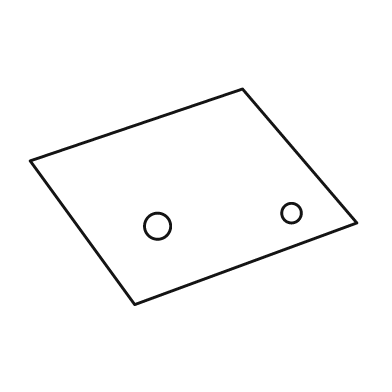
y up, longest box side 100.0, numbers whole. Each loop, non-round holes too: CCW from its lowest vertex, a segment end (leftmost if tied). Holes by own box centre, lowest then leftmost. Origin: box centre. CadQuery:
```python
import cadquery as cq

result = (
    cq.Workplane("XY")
    .moveTo(-18.0, -33.0)
    .lineTo(50.0, -8.0)
    .lineTo(15.0, 33.0)
    .lineTo(-50.0, 11.0)
    .close()
    .moveTo(-11.0, -9.0)
    .circle(4.0)
    .moveTo(30.0, -5.0)
    .circle(3.0)
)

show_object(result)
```